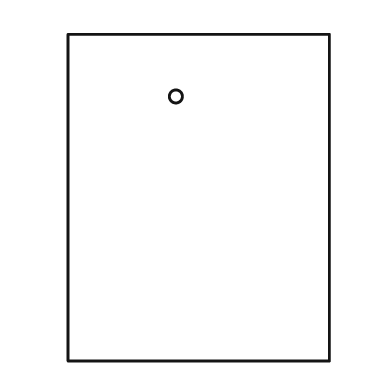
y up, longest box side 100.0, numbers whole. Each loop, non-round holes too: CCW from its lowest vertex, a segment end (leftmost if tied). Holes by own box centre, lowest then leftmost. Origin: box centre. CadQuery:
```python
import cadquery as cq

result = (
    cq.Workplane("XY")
    .moveTo(-40.0, -50.0)
    .lineTo(40.0, -50.0)
    .lineTo(40.0, 50.0)
    .lineTo(-40.0, 50.0)
    .close()
    .moveTo(-7.0, 31.0)
    .circle(2.0)
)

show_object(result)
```